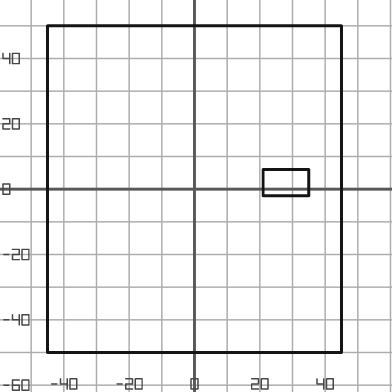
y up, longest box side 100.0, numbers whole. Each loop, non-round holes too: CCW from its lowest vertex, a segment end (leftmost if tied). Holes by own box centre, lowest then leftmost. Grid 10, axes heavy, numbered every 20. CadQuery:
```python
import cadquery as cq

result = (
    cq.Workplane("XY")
    .moveTo(-45.0, -50.0)
    .lineTo(45.0, -50.0)
    .lineTo(45.0, 50.0)
    .lineTo(-45.0, 50.0)
    .close()
    .moveTo(21.0, -2.0)
    .lineTo(35.0, -2.0)
    .lineTo(35.0, 6.0)
    .lineTo(21.0, 6.0)
    .close()
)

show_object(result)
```